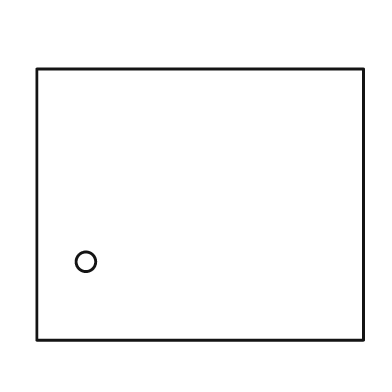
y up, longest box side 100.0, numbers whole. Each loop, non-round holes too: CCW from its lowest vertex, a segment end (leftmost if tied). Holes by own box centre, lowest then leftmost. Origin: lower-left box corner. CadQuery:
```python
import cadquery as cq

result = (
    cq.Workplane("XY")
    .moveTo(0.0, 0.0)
    .lineTo(100.0, 0.0)
    .lineTo(100.0, 83.0)
    .lineTo(0.0, 83.0)
    .close()
    .moveTo(15.0, 24.0)
    .circle(3.0)
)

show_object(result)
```